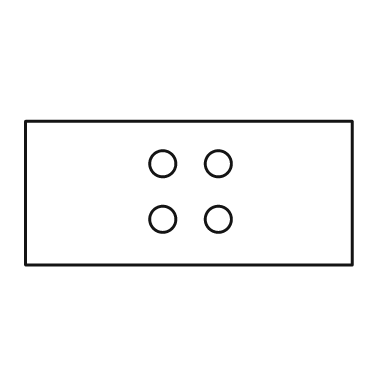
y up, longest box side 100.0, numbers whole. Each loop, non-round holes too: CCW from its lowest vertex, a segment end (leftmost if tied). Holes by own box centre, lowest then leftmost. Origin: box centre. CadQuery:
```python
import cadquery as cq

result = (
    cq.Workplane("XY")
    .moveTo(-50.0, -22.0)
    .lineTo(50.0, -22.0)
    .lineTo(50.0, 22.0)
    .lineTo(-50.0, 22.0)
    .close()
    .moveTo(-8.0, -8.0)
    .circle(4.0)
    .moveTo(9.0, -8.0)
    .circle(4.0)
    .moveTo(-8.0, 9.0)
    .circle(4.0)
    .moveTo(9.0, 9.0)
    .circle(4.0)
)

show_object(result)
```